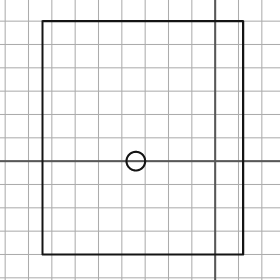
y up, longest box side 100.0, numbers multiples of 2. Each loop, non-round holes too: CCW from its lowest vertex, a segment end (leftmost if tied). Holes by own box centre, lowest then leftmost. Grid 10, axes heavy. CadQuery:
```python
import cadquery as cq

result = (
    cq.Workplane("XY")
    .moveTo(-74.0, -40.0)
    .lineTo(12.0, -40.0)
    .lineTo(12.0, 60.0)
    .lineTo(-74.0, 60.0)
    .close()
    .moveTo(-34.0, 0.0)
    .circle(4.0)
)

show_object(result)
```